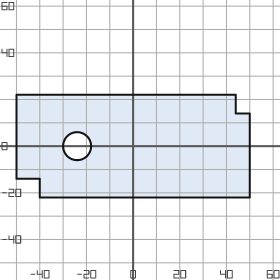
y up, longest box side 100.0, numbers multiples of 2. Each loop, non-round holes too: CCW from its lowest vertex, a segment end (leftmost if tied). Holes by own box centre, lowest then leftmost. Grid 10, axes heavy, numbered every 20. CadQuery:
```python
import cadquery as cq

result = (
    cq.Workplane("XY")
    .moveTo(-40.0, -22.0)
    .lineTo(50.0, -22.0)
    .lineTo(50.0, 14.0)
    .lineTo(44.0, 14.0)
    .lineTo(44.0, 22.0)
    .lineTo(-50.0, 22.0)
    .lineTo(-50.0, -14.0)
    .lineTo(-40.0, -14.0)
    .close()
    .moveTo(-24.0, 0.0)
    .circle(6.0)
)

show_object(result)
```